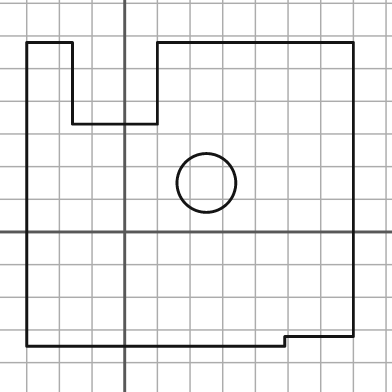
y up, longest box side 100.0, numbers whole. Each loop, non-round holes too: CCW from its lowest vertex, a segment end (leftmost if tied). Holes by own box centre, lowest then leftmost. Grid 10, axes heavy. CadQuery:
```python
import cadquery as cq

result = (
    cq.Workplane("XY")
    .moveTo(-30.0, -35.0)
    .lineTo(49.0, -35.0)
    .lineTo(49.0, -32.0)
    .lineTo(70.0, -32.0)
    .lineTo(70.0, 58.0)
    .lineTo(10.0, 58.0)
    .lineTo(10.0, 33.0)
    .lineTo(-16.0, 33.0)
    .lineTo(-16.0, 58.0)
    .lineTo(-30.0, 58.0)
    .close()
    .moveTo(25.0, 15.0)
    .circle(9.0)
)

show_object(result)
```